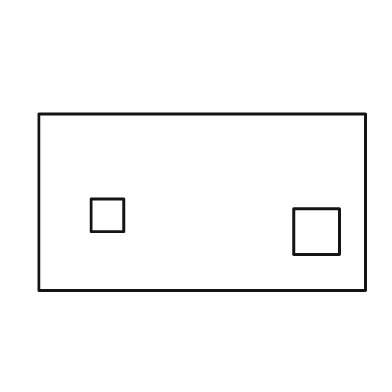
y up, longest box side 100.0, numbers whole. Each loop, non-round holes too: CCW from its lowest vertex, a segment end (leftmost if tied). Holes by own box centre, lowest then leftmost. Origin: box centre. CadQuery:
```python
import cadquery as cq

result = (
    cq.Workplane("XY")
    .moveTo(-50.0, -27.0)
    .lineTo(50.0, -27.0)
    .lineTo(50.0, 27.0)
    .lineTo(-50.0, 27.0)
    .close()
    .moveTo(28.0, -16.0)
    .lineTo(42.0, -16.0)
    .lineTo(42.0, -2.0)
    .lineTo(28.0, -2.0)
    .close()
    .moveTo(-34.0, -9.0)
    .lineTo(-24.0, -9.0)
    .lineTo(-24.0, 1.0)
    .lineTo(-34.0, 1.0)
    .close()
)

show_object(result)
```